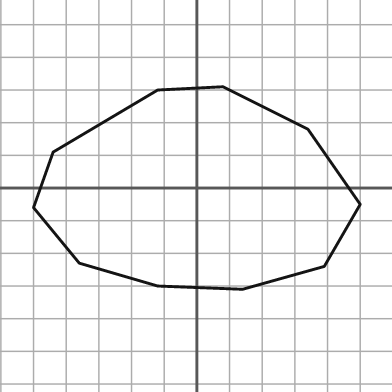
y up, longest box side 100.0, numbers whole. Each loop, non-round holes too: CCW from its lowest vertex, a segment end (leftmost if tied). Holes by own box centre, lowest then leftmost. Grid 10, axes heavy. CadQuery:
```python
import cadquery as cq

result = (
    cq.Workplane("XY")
    .moveTo(14.0, -31.0)
    .lineTo(39.0, -24.0)
    .lineTo(50.0, -5.0)
    .lineTo(34.0, 18.0)
    .lineTo(8.0, 31.0)
    .lineTo(-12.0, 30.0)
    .lineTo(-44.0, 11.0)
    .lineTo(-50.0, -6.0)
    .lineTo(-36.0, -23.0)
    .lineTo(-12.0, -30.0)
    .close()
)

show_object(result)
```